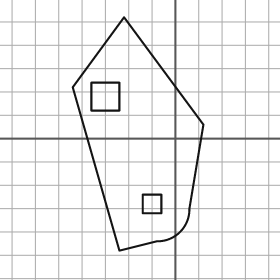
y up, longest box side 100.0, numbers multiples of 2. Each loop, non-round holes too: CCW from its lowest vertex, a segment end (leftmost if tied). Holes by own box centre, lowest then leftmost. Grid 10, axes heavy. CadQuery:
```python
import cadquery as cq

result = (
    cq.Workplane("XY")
    .moveTo(-24.0, -48.0)
    .lineTo(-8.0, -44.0)
    .threePointArc((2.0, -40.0), (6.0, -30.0))
    .lineTo(12.0, 6.0)
    .lineTo(-22.0, 52.0)
    .lineTo(-44.0, 22.0)
    .close()
    .moveTo(-14.0, -32.0)
    .lineTo(-6.0, -32.0)
    .lineTo(-6.0, -24.0)
    .lineTo(-14.0, -24.0)
    .close()
    .moveTo(-36.0, 12.0)
    .lineTo(-24.0, 12.0)
    .lineTo(-24.0, 24.0)
    .lineTo(-36.0, 24.0)
    .close()
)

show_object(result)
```